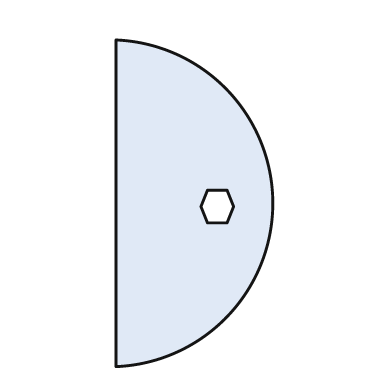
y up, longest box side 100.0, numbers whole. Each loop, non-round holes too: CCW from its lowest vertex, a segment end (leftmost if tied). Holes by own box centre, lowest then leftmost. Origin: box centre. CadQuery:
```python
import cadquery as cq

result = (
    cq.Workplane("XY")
    .moveTo(-24.0, -50.0)
    .threePointArc((24.0, 0.0), (-24.0, 50.0))
    .close()
    .moveTo(4.0, -6.0)
    .lineTo(10.0, -6.0)
    .lineTo(12.0, -1.0)
    .lineTo(10.0, 4.0)
    .lineTo(4.0, 4.0)
    .lineTo(2.0, -1.0)
    .close()
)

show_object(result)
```